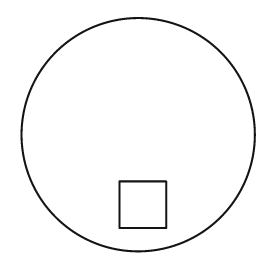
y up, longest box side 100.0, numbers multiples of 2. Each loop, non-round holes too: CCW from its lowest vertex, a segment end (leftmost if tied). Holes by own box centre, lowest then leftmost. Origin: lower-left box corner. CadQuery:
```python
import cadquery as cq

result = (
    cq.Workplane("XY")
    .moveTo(50.0, 50.0)
    .circle(50.0)
    .moveTo(42.0, 10.0)
    .lineTo(62.0, 10.0)
    .lineTo(62.0, 30.0)
    .lineTo(42.0, 30.0)
    .close()
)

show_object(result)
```